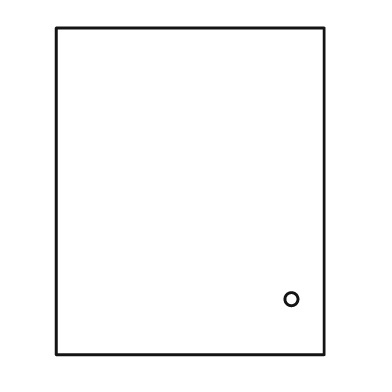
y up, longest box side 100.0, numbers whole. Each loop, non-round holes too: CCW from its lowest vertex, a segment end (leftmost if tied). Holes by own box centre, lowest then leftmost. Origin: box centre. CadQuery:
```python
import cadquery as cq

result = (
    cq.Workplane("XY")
    .moveTo(-41.0, -50.0)
    .lineTo(41.0, -50.0)
    .lineTo(41.0, 50.0)
    .lineTo(-41.0, 50.0)
    .close()
    .moveTo(31.0, -33.0)
    .circle(2.0)
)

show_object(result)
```